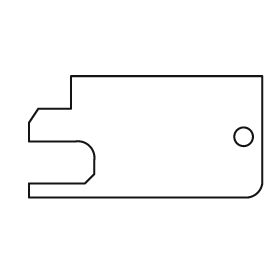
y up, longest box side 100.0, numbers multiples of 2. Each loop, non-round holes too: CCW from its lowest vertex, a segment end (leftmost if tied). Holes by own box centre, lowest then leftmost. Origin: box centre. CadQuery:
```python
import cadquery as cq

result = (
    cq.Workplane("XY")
    .moveTo(-50.0, -26.0)
    .lineTo(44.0, -26.0)
    .threePointArc((48.0, -24.0), (50.0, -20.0))
    .lineTo(50.0, 26.0)
    .lineTo(-32.0, 26.0)
    .lineTo(-32.0, 12.0)
    .lineTo(-46.0, 12.0)
    .lineTo(-50.0, 6.0)
    .lineTo(-50.0, -2.0)
    .lineTo(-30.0, -2.0)
    .threePointArc((-24.0, -4.0), (-22.0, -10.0))
    .lineTo(-22.0, -16.0)
    .lineTo(-26.0, -20.0)
    .lineTo(-50.0, -20.0)
    .close()
    .moveTo(42.0, 0.0)
    .circle(4.0)
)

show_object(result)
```